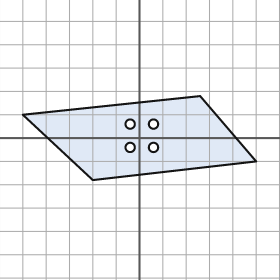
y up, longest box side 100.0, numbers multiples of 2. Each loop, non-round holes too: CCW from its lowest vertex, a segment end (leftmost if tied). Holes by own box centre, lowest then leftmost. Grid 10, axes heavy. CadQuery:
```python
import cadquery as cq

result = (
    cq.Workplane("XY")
    .moveTo(-20.0, -18.0)
    .lineTo(50.0, -10.0)
    .lineTo(26.0, 18.0)
    .lineTo(-50.0, 10.0)
    .close()
    .moveTo(-4.0, -4.0)
    .circle(2.0)
    .moveTo(6.0, -4.0)
    .circle(2.0)
    .moveTo(-4.0, 6.0)
    .circle(2.0)
    .moveTo(6.0, 6.0)
    .circle(2.0)
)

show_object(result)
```